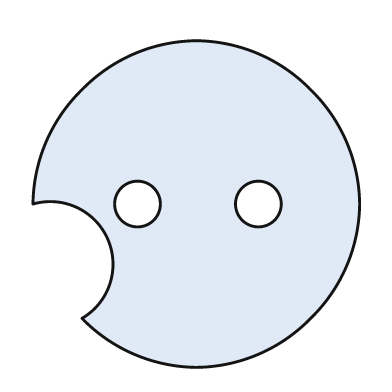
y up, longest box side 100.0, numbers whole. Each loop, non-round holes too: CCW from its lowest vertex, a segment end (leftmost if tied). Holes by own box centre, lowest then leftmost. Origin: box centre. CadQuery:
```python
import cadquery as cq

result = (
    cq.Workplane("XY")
    .moveTo(0.0, -50.0)
    .threePointArc((19.0, -46.0), (35.0, -35.0))
    .threePointArc((46.0, -19.0), (50.0, 0.0))
    .threePointArc((46.0, 19.0), (35.0, 35.0))
    .threePointArc((19.0, 46.0), (0.0, 50.0))
    .threePointArc((-19.0, 46.0), (-35.0, 35.0))
    .threePointArc((-46.0, 19.0), (-50.0, 0.0))
    .threePointArc((-27.0, -11.0), (-35.0, -35.0))
    .threePointArc((-19.0, -46.0), (0.0, -50.0))
    .close()
    .moveTo(-18.0, 0.0)
    .circle(7.0)
    .moveTo(19.0, 0.0)
    .circle(7.0)
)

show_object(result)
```